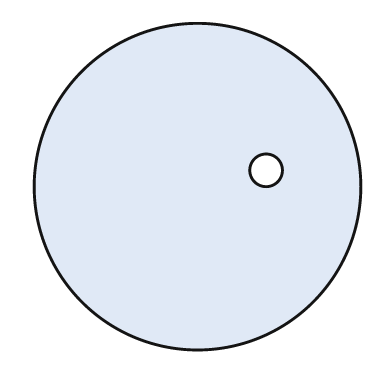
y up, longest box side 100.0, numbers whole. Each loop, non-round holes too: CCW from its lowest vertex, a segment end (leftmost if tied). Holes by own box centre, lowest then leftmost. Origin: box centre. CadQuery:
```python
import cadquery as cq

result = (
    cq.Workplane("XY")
    .moveTo(0.0, 0.0)
    .circle(50.0)
    .moveTo(21.0, 5.0)
    .circle(5.0)
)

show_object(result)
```